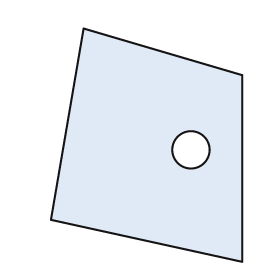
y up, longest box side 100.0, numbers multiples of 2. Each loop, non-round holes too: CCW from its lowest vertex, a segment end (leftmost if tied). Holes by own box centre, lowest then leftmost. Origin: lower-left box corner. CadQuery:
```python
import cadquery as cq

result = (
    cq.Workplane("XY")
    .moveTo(82.0, 0.0)
    .lineTo(82.0, 80.0)
    .lineTo(14.0, 100.0)
    .lineTo(0.0, 18.0)
    .close()
    .moveTo(60.0, 48.0)
    .circle(8.0)
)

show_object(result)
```